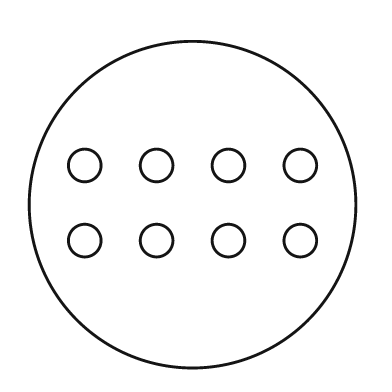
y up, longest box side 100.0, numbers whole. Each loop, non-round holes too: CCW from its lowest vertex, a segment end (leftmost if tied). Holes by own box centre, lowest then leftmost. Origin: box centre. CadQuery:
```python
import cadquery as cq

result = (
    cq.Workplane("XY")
    .moveTo(0.0, 0.0)
    .circle(50.0)
    .moveTo(-33.0, -11.0)
    .circle(5.0)
    .moveTo(-11.0, -11.0)
    .circle(5.0)
    .moveTo(11.0, -11.0)
    .circle(5.0)
    .moveTo(33.0, -11.0)
    .circle(5.0)
    .moveTo(-33.0, 12.0)
    .circle(5.0)
    .moveTo(-11.0, 12.0)
    .circle(5.0)
    .moveTo(11.0, 12.0)
    .circle(5.0)
    .moveTo(33.0, 12.0)
    .circle(5.0)
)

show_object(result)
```